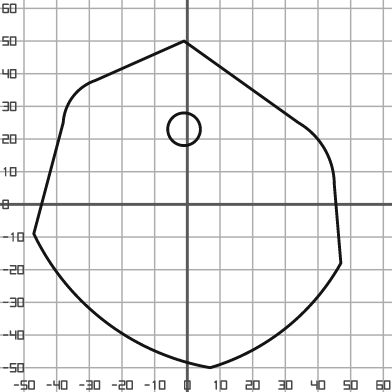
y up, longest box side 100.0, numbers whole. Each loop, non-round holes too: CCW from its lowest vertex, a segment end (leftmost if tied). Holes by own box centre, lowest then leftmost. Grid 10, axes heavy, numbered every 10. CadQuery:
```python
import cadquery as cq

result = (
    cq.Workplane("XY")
    .moveTo(7.0, -50.0)
    .threePointArc((30.0, -38.0), (47.0, -18.0))
    .lineTo(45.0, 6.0)
    .threePointArc((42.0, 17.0), (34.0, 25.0))
    .lineTo(-1.0, 50.0)
    .lineTo(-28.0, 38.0)
    .threePointArc((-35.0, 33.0), (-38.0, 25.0))
    .lineTo(-47.0, -9.0)
    .threePointArc((-25.0, -36.0), (7.0, -50.0))
    .close()
    .moveTo(-1.0, 23.0)
    .circle(5.0)
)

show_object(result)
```